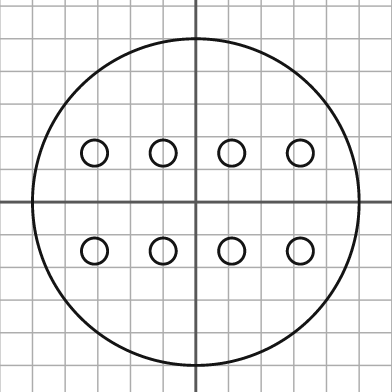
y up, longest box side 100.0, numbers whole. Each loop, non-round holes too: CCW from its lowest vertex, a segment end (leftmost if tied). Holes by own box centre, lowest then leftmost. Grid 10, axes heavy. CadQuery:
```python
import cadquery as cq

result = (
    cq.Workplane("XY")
    .moveTo(0.0, 0.0)
    .circle(50.0)
    .moveTo(-31.0, -15.0)
    .circle(4.0)
    .moveTo(-10.0, -15.0)
    .circle(4.0)
    .moveTo(11.0, -15.0)
    .circle(4.0)
    .moveTo(32.0, -15.0)
    .circle(4.0)
    .moveTo(-31.0, 15.0)
    .circle(4.0)
    .moveTo(-10.0, 15.0)
    .circle(4.0)
    .moveTo(11.0, 15.0)
    .circle(4.0)
    .moveTo(32.0, 15.0)
    .circle(4.0)
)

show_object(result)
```